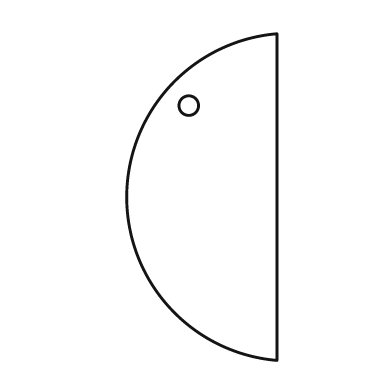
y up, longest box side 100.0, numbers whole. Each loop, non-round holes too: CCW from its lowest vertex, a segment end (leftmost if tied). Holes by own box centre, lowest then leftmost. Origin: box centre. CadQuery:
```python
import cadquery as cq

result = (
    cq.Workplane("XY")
    .moveTo(23.0, -50.0)
    .lineTo(23.0, 50.0)
    .threePointArc((-23.0, 0.0), (23.0, -50.0))
    .close()
    .moveTo(-4.0, 28.0)
    .circle(3.0)
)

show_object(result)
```